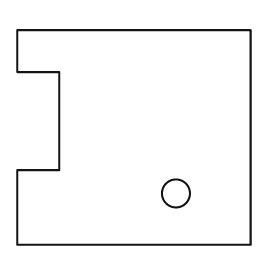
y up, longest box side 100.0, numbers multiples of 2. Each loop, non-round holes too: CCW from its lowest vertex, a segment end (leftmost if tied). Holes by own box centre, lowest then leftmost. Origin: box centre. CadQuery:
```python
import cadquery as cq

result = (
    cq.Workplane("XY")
    .moveTo(-50.0, -46.0)
    .lineTo(50.0, -46.0)
    .lineTo(50.0, 46.0)
    .lineTo(-50.0, 46.0)
    .lineTo(-50.0, 28.0)
    .lineTo(-32.0, 28.0)
    .lineTo(-32.0, -14.0)
    .lineTo(-50.0, -14.0)
    .close()
    .moveTo(18.0, -24.0)
    .circle(6.0)
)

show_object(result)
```